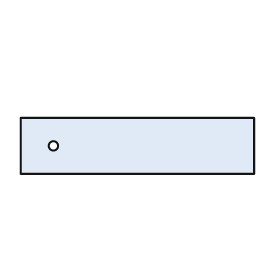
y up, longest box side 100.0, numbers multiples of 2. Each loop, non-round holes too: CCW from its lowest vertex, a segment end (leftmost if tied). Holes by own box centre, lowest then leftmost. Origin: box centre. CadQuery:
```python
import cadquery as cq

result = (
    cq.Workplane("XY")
    .moveTo(-50.0, -12.0)
    .lineTo(50.0, -12.0)
    .lineTo(50.0, 12.0)
    .lineTo(-50.0, 12.0)
    .close()
    .moveTo(-36.0, 0.0)
    .circle(2.0)
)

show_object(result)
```